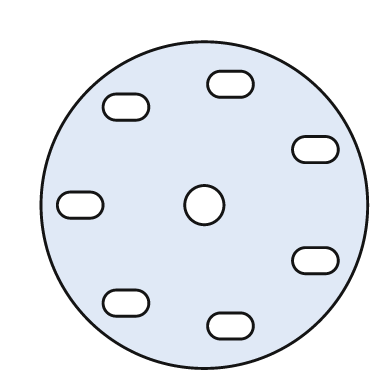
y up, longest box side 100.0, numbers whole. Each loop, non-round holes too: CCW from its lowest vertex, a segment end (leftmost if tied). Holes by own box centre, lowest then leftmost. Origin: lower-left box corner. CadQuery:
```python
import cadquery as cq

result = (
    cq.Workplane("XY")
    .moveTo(50.0, 50.0)
    .circle(50.0)
    .moveTo(55.0, 9.0)
    .lineTo(61.0, 9.0)
    .threePointArc((65.0, 13.0), (61.0, 17.0))
    .lineTo(55.0, 17.0)
    .threePointArc((51.0, 13.0), (55.0, 9.0))
    .close()
    .moveTo(23.0, 16.0)
    .lineTo(29.0, 16.0)
    .threePointArc((33.0, 20.0), (29.0, 24.0))
    .lineTo(23.0, 24.0)
    .threePointArc((19.0, 20.0), (23.0, 16.0))
    .close()
    .moveTo(81.0, 29.0)
    .lineTo(87.0, 29.0)
    .threePointArc((91.0, 33.0), (87.0, 37.0))
    .lineTo(81.0, 37.0)
    .threePointArc((77.0, 33.0), (81.0, 29.0))
    .close()
    .moveTo(9.0, 46.0)
    .lineTo(15.0, 46.0)
    .threePointArc((19.0, 50.0), (15.0, 54.0))
    .lineTo(9.0, 54.0)
    .threePointArc((5.0, 50.0), (9.0, 46.0))
    .close()
    .moveTo(50.0, 50.0)
    .circle(6.0)
    .moveTo(81.0, 63.0)
    .lineTo(87.0, 63.0)
    .threePointArc((91.0, 67.0), (87.0, 71.0))
    .lineTo(81.0, 71.0)
    .threePointArc((77.0, 67.0), (81.0, 63.0))
    .close()
    .moveTo(23.0, 76.0)
    .lineTo(29.0, 76.0)
    .threePointArc((33.0, 80.0), (29.0, 84.0))
    .lineTo(23.0, 84.0)
    .threePointArc((19.0, 80.0), (23.0, 76.0))
    .close()
    .moveTo(55.0, 83.0)
    .lineTo(61.0, 83.0)
    .threePointArc((65.0, 87.0), (61.0, 91.0))
    .lineTo(55.0, 91.0)
    .threePointArc((51.0, 87.0), (55.0, 83.0))
    .close()
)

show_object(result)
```